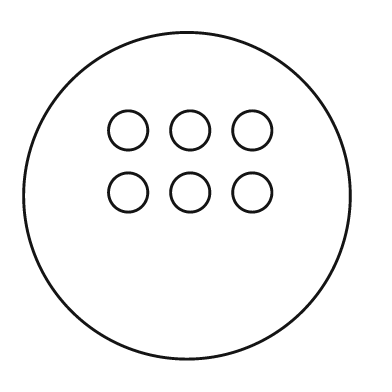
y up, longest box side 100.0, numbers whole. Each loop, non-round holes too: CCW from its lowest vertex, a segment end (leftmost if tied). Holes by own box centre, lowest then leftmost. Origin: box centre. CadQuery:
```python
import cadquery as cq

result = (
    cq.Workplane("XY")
    .moveTo(0.0, 0.0)
    .circle(50.0)
    .moveTo(-18.0, 1.0)
    .circle(6.0)
    .moveTo(1.0, 1.0)
    .circle(6.0)
    .moveTo(20.0, 1.0)
    .circle(6.0)
    .moveTo(-18.0, 20.0)
    .circle(6.0)
    .moveTo(1.0, 20.0)
    .circle(6.0)
    .moveTo(20.0, 20.0)
    .circle(6.0)
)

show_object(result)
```